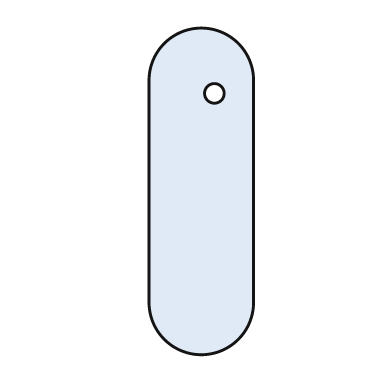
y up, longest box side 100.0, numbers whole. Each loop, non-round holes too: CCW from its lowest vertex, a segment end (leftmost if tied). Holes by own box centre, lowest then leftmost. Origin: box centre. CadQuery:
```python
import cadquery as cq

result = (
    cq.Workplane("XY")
    .moveTo(-16.0, -34.0)
    .threePointArc((0.0, -50.0), (16.0, -34.0))
    .lineTo(16.0, 34.0)
    .threePointArc((0.0, 50.0), (-16.0, 34.0))
    .close()
    .moveTo(4.0, 30.0)
    .circle(3.0)
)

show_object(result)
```